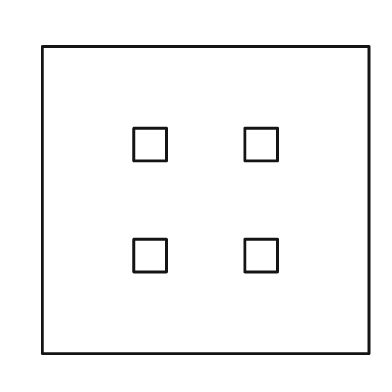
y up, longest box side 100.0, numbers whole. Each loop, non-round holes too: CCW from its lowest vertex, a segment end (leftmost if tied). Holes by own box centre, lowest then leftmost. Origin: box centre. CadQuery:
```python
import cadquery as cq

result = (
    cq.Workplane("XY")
    .moveTo(-50.0, -47.0)
    .lineTo(50.0, -47.0)
    .lineTo(50.0, 47.0)
    .lineTo(-50.0, 47.0)
    .close()
    .moveTo(-22.0, -22.0)
    .lineTo(-12.0, -22.0)
    .lineTo(-12.0, -12.0)
    .lineTo(-22.0, -12.0)
    .close()
    .moveTo(12.0, -22.0)
    .lineTo(22.0, -22.0)
    .lineTo(22.0, -12.0)
    .lineTo(12.0, -12.0)
    .close()
    .moveTo(-22.0, 12.0)
    .lineTo(-12.0, 12.0)
    .lineTo(-12.0, 22.0)
    .lineTo(-22.0, 22.0)
    .close()
    .moveTo(12.0, 12.0)
    .lineTo(22.0, 12.0)
    .lineTo(22.0, 22.0)
    .lineTo(12.0, 22.0)
    .close()
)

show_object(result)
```